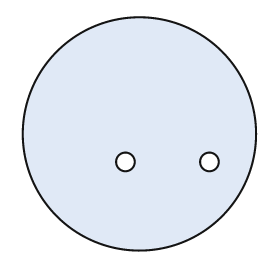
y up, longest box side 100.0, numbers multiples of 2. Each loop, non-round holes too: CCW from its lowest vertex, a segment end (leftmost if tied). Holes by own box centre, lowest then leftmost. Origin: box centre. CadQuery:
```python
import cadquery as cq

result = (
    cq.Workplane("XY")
    .moveTo(0.0, 0.0)
    .circle(50.0)
    .moveTo(-6.0, -12.0)
    .circle(4.0)
    .moveTo(30.0, -12.0)
    .circle(4.0)
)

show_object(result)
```